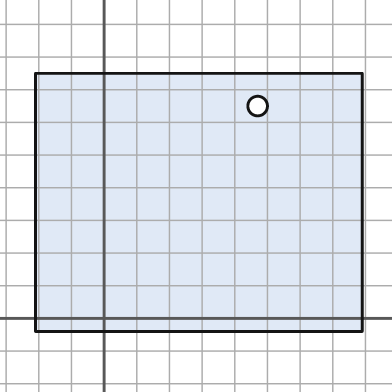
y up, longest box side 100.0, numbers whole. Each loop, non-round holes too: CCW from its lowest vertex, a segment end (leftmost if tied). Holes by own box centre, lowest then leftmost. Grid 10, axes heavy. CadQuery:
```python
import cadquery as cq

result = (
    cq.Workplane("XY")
    .moveTo(-21.0, -4.0)
    .lineTo(79.0, -4.0)
    .lineTo(79.0, 75.0)
    .lineTo(-21.0, 75.0)
    .close()
    .moveTo(47.0, 65.0)
    .circle(3.0)
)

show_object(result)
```